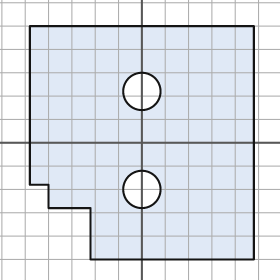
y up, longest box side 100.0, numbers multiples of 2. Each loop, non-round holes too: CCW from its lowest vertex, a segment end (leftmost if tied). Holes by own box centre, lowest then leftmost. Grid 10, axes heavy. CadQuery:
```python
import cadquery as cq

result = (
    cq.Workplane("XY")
    .moveTo(-22.0, -50.0)
    .lineTo(48.0, -50.0)
    .lineTo(48.0, 50.0)
    .lineTo(-48.0, 50.0)
    .lineTo(-48.0, -18.0)
    .lineTo(-40.0, -18.0)
    .lineTo(-40.0, -28.0)
    .lineTo(-22.0, -28.0)
    .close()
    .moveTo(0.0, -20.0)
    .circle(8.0)
    .moveTo(0.0, 22.0)
    .circle(8.0)
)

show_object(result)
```